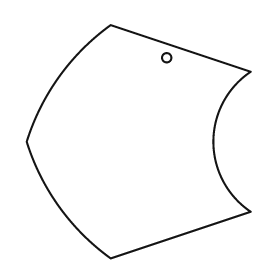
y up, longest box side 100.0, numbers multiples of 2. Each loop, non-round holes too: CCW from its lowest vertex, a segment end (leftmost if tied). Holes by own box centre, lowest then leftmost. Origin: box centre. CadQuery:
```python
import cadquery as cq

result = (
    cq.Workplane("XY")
    .moveTo(-12.0, -50.0)
    .lineTo(48.0, -30.0)
    .threePointArc((32.0, 0.0), (48.0, 30.0))
    .lineTo(-12.0, 50.0)
    .threePointArc((-34.0, 28.0), (-48.0, 0.0))
    .threePointArc((-34.0, -28.0), (-12.0, -50.0))
    .close()
    .moveTo(12.0, 36.0)
    .circle(2.0)
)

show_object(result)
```